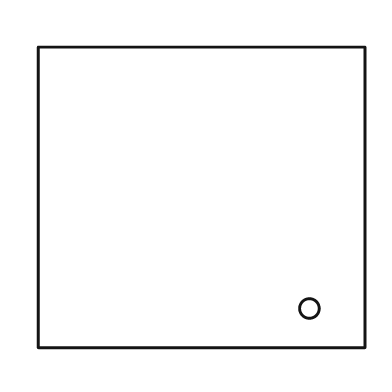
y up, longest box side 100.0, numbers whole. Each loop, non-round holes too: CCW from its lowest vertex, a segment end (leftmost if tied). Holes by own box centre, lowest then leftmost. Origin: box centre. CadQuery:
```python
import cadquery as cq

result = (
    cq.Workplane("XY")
    .moveTo(-50.0, -46.0)
    .lineTo(50.0, -46.0)
    .lineTo(50.0, 46.0)
    .lineTo(-50.0, 46.0)
    .close()
    .moveTo(33.0, -34.0)
    .circle(3.0)
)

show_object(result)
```